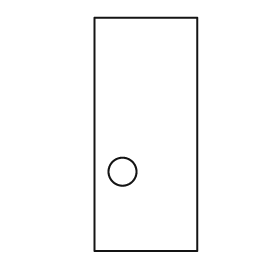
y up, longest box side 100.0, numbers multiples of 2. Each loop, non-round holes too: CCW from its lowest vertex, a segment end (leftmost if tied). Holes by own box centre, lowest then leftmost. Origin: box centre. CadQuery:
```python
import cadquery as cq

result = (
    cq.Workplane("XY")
    .moveTo(-22.0, -50.0)
    .lineTo(22.0, -50.0)
    .lineTo(22.0, 50.0)
    .lineTo(-22.0, 50.0)
    .close()
    .moveTo(-10.0, -16.0)
    .circle(6.0)
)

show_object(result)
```